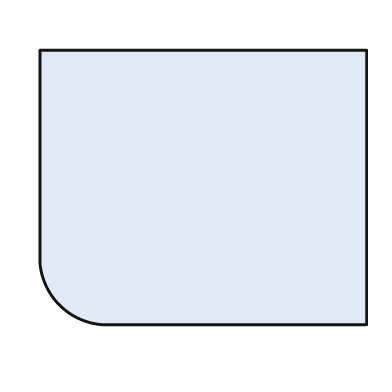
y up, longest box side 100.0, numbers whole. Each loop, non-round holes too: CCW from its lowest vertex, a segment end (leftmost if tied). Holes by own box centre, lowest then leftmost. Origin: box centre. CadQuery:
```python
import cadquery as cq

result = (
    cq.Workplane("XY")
    .moveTo(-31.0, -42.0)
    .lineTo(50.0, -42.0)
    .lineTo(50.0, 42.0)
    .lineTo(-50.0, 42.0)
    .lineTo(-50.0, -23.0)
    .threePointArc((-44.0, -36.0), (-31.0, -42.0))
    .close()
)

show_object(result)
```